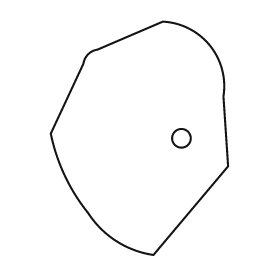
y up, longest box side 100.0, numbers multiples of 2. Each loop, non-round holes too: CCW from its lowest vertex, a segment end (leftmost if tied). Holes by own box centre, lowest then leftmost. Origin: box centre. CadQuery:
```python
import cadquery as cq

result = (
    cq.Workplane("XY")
    .moveTo(6.0, -50.0)
    .lineTo(38.0, -12.0)
    .lineTo(36.0, 18.0)
    .threePointArc((30.0, 40.0), (10.0, 50.0))
    .lineTo(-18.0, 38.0)
    .threePointArc((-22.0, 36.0), (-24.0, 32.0))
    .lineTo(-38.0, 2.0)
    .threePointArc((-32.0, -16.0), (-22.0, -32.0))
    .threePointArc((-10.0, -44.0), (6.0, -50.0))
    .close()
    .moveTo(18.0, 0.0)
    .circle(4.0)
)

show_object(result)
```